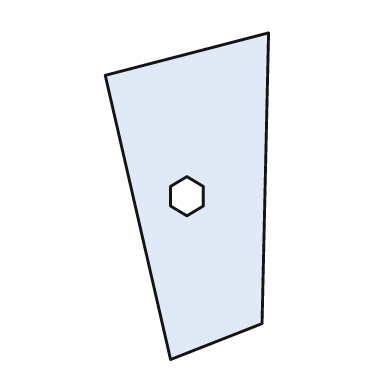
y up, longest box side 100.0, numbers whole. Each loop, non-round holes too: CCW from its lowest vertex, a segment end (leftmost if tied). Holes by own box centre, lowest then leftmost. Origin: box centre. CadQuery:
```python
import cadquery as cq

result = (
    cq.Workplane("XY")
    .moveTo(-5.0, -50.0)
    .lineTo(23.0, -39.0)
    .lineTo(25.0, 50.0)
    .lineTo(-25.0, 37.0)
    .close()
    .moveTo(0.0, -6.0)
    .lineTo(5.0, -3.0)
    .lineTo(5.0, 3.0)
    .lineTo(0.0, 6.0)
    .lineTo(-5.0, 3.0)
    .lineTo(-5.0, -3.0)
    .close()
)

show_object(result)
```